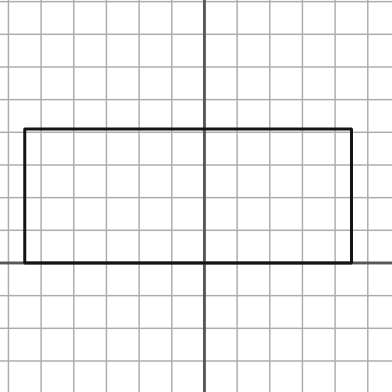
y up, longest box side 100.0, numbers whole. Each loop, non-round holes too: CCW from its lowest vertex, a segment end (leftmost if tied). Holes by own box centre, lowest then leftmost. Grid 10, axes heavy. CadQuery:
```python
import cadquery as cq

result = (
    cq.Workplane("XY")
    .moveTo(-55.0, 0.0)
    .lineTo(45.0, 0.0)
    .lineTo(45.0, 41.0)
    .lineTo(-55.0, 41.0)
    .close()
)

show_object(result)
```